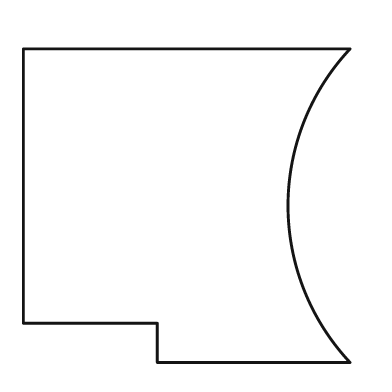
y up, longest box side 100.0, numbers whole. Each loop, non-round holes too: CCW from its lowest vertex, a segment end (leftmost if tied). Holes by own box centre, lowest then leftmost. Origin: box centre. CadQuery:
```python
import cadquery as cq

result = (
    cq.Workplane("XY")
    .moveTo(-9.0, -48.0)
    .lineTo(50.0, -48.0)
    .threePointArc((31.0, 0.0), (50.0, 48.0))
    .lineTo(-50.0, 48.0)
    .lineTo(-50.0, -36.0)
    .lineTo(-9.0, -36.0)
    .close()
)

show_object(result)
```